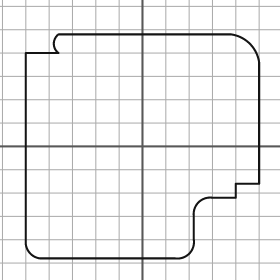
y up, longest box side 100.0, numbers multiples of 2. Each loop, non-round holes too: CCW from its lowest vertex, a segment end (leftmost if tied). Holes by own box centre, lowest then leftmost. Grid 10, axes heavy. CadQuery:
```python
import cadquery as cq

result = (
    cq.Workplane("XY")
    .moveTo(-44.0, -48.0)
    .lineTo(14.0, -48.0)
    .threePointArc((20.0, -46.0), (22.0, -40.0))
    .lineTo(22.0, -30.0)
    .threePointArc((24.0, -24.0), (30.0, -22.0))
    .lineTo(40.0, -22.0)
    .lineTo(40.0, -16.0)
    .lineTo(50.0, -16.0)
    .lineTo(50.0, 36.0)
    .threePointArc((46.0, 44.0), (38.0, 48.0))
    .lineTo(-36.0, 48.0)
    .threePointArc((-38.0, 44.0), (-36.0, 40.0))
    .lineTo(-50.0, 40.0)
    .lineTo(-50.0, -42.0)
    .threePointArc((-48.0, -46.0), (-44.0, -48.0))
    .close()
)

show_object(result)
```